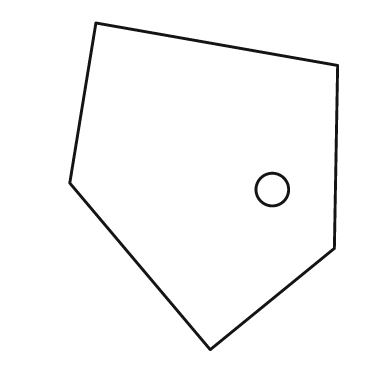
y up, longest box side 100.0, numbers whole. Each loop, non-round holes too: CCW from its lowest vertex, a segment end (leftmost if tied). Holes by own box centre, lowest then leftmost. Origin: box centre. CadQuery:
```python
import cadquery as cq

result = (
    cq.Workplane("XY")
    .moveTo(2.0, -50.0)
    .lineTo(40.0, -19.0)
    .lineTo(41.0, 37.0)
    .lineTo(-33.0, 50.0)
    .lineTo(-41.0, 1.0)
    .close()
    .moveTo(21.0, -1.0)
    .circle(5.0)
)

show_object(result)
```